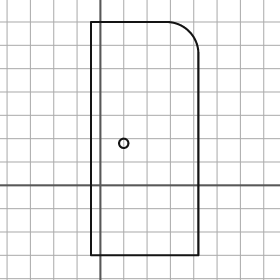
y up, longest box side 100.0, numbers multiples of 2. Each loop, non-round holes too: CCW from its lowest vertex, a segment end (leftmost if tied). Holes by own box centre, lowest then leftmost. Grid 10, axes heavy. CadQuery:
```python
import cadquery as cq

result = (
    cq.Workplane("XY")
    .moveTo(-4.0, -30.0)
    .lineTo(42.0, -30.0)
    .lineTo(42.0, 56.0)
    .threePointArc((38.0, 66.0), (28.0, 70.0))
    .lineTo(-4.0, 70.0)
    .close()
    .moveTo(10.0, 18.0)
    .circle(2.0)
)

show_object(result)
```